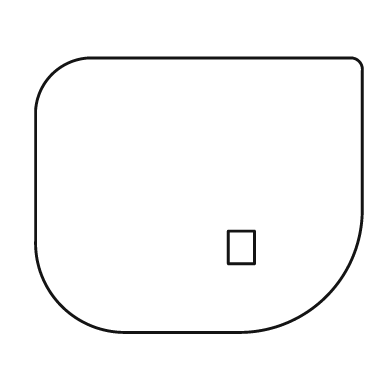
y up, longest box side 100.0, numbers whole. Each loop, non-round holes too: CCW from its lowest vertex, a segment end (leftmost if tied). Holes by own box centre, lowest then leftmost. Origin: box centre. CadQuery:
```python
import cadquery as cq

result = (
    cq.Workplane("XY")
    .moveTo(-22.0, -42.0)
    .lineTo(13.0, -42.0)
    .threePointArc((39.0, -31.0), (50.0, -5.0))
    .lineTo(50.0, 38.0)
    .threePointArc((49.0, 41.0), (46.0, 42.0))
    .lineTo(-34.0, 42.0)
    .threePointArc((-45.0, 37.0), (-50.0, 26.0))
    .lineTo(-50.0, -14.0)
    .threePointArc((-42.0, -34.0), (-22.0, -42.0))
    .close()
    .moveTo(9.0, -21.0)
    .lineTo(17.0, -21.0)
    .lineTo(17.0, -11.0)
    .lineTo(9.0, -11.0)
    .close()
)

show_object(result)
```